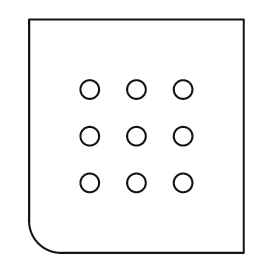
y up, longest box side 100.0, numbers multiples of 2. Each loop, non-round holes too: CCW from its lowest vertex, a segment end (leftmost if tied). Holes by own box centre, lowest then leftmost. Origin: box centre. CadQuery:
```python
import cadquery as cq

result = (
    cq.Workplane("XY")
    .moveTo(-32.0, -50.0)
    .lineTo(46.0, -50.0)
    .lineTo(46.0, 50.0)
    .lineTo(-46.0, 50.0)
    .lineTo(-46.0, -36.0)
    .threePointArc((-42.0, -46.0), (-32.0, -50.0))
    .close()
    .moveTo(-20.0, -20.0)
    .circle(4.0)
    .moveTo(0.0, -20.0)
    .circle(4.0)
    .moveTo(20.0, -20.0)
    .circle(4.0)
    .moveTo(-20.0, 0.0)
    .circle(4.0)
    .moveTo(0.0, 0.0)
    .circle(4.0)
    .moveTo(20.0, 0.0)
    .circle(4.0)
    .moveTo(-20.0, 20.0)
    .circle(4.0)
    .moveTo(0.0, 20.0)
    .circle(4.0)
    .moveTo(20.0, 20.0)
    .circle(4.0)
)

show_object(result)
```